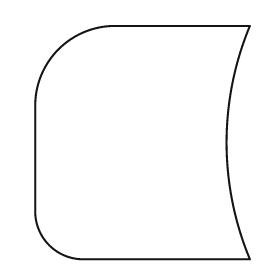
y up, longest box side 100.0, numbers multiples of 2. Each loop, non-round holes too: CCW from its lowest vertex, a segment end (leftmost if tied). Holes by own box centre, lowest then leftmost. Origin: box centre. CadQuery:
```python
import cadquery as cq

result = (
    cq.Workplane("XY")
    .moveTo(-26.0, -50.0)
    .lineTo(46.0, -50.0)
    .threePointArc((36.0, 0.0), (46.0, 50.0))
    .lineTo(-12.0, 50.0)
    .threePointArc((-36.0, 40.0), (-46.0, 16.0))
    .lineTo(-46.0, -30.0)
    .threePointArc((-40.0, -44.0), (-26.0, -50.0))
    .close()
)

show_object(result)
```